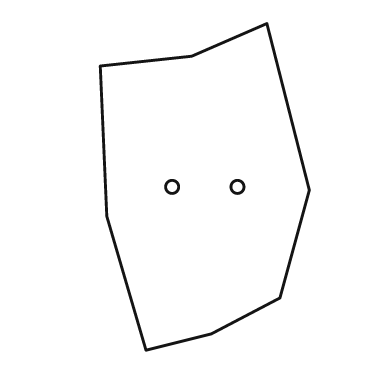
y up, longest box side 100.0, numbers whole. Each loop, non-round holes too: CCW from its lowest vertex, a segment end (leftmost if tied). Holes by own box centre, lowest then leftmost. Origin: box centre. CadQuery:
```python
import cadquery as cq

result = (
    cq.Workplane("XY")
    .moveTo(-18.0, -50.0)
    .lineTo(2.0, -45.0)
    .lineTo(23.0, -34.0)
    .lineTo(32.0, -1.0)
    .lineTo(19.0, 50.0)
    .lineTo(-4.0, 40.0)
    .lineTo(-32.0, 37.0)
    .lineTo(-30.0, -9.0)
    .close()
    .moveTo(-10.0, 0.0)
    .circle(2.0)
    .moveTo(10.0, 0.0)
    .circle(2.0)
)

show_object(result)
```